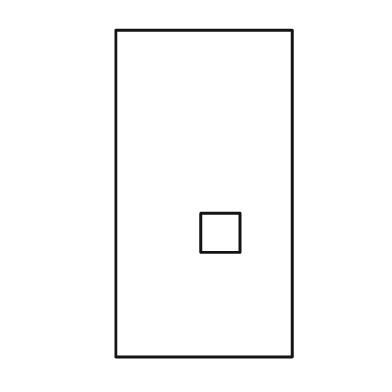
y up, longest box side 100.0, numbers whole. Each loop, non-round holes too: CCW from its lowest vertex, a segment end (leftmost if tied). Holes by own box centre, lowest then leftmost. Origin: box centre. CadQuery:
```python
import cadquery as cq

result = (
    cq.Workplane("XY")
    .moveTo(-27.0, -50.0)
    .lineTo(27.0, -50.0)
    .lineTo(27.0, 50.0)
    .lineTo(-27.0, 50.0)
    .close()
    .moveTo(-1.0, -18.0)
    .lineTo(11.0, -18.0)
    .lineTo(11.0, -6.0)
    .lineTo(-1.0, -6.0)
    .close()
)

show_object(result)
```